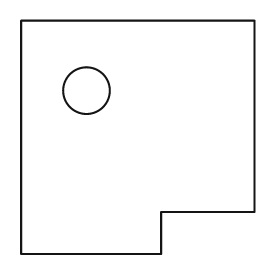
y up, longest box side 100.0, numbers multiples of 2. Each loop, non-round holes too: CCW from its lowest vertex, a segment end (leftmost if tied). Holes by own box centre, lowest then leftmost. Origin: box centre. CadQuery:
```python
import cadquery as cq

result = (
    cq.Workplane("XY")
    .moveTo(-50.0, -50.0)
    .lineTo(10.0, -50.0)
    .lineTo(10.0, -32.0)
    .lineTo(50.0, -32.0)
    .lineTo(50.0, 50.0)
    .lineTo(-50.0, 50.0)
    .close()
    .moveTo(-22.0, 20.0)
    .circle(10.0)
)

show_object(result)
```